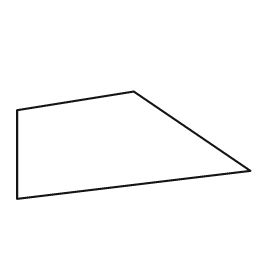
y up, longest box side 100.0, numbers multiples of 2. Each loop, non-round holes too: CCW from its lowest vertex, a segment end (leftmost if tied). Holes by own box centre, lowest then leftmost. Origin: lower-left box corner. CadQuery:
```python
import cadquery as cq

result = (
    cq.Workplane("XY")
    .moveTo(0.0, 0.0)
    .lineTo(100.0, 12.0)
    .lineTo(50.0, 46.0)
    .lineTo(0.0, 38.0)
    .close()
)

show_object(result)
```